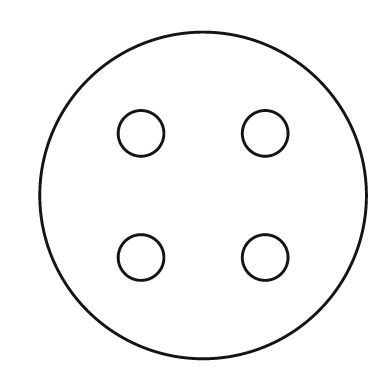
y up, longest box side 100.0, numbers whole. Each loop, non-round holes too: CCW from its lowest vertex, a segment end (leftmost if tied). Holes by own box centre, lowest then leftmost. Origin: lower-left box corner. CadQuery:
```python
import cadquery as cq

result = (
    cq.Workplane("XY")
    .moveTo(50.0, 50.0)
    .circle(50.0)
    .moveTo(31.0, 31.0)
    .circle(7.0)
    .moveTo(69.0, 31.0)
    .circle(7.0)
    .moveTo(31.0, 69.0)
    .circle(7.0)
    .moveTo(69.0, 69.0)
    .circle(7.0)
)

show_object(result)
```